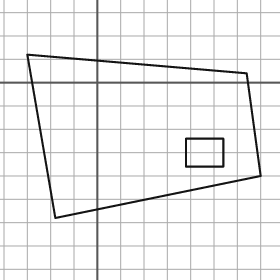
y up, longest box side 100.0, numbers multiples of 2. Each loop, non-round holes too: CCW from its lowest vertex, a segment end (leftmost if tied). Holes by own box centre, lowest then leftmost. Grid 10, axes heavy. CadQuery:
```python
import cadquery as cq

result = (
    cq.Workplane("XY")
    .moveTo(-18.0, -58.0)
    .lineTo(70.0, -40.0)
    .lineTo(64.0, 4.0)
    .lineTo(-30.0, 12.0)
    .close()
    .moveTo(38.0, -36.0)
    .lineTo(54.0, -36.0)
    .lineTo(54.0, -24.0)
    .lineTo(38.0, -24.0)
    .close()
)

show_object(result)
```